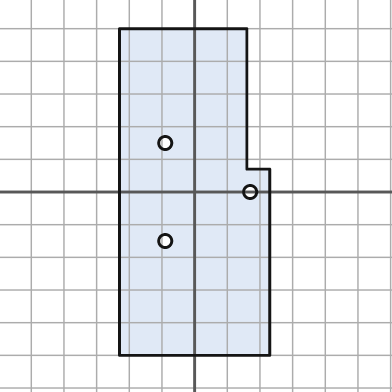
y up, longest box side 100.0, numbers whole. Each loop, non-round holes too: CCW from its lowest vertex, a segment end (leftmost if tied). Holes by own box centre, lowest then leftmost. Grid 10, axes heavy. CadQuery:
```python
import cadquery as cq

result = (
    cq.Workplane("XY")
    .moveTo(-23.0, -50.0)
    .lineTo(23.0, -50.0)
    .lineTo(23.0, 7.0)
    .lineTo(16.0, 7.0)
    .lineTo(16.0, 50.0)
    .lineTo(-23.0, 50.0)
    .close()
    .moveTo(-9.0, -15.0)
    .circle(2.0)
    .moveTo(17.0, 0.0)
    .circle(2.0)
    .moveTo(-9.0, 15.0)
    .circle(2.0)
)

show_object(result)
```